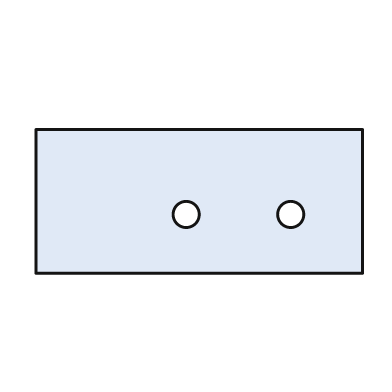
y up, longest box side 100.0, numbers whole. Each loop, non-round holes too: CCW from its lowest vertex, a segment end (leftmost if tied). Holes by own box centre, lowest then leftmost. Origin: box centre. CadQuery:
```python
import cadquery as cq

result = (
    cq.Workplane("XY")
    .moveTo(-50.0, -22.0)
    .lineTo(50.0, -22.0)
    .lineTo(50.0, 22.0)
    .lineTo(-50.0, 22.0)
    .close()
    .moveTo(-4.0, -4.0)
    .circle(4.0)
    .moveTo(28.0, -4.0)
    .circle(4.0)
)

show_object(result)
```